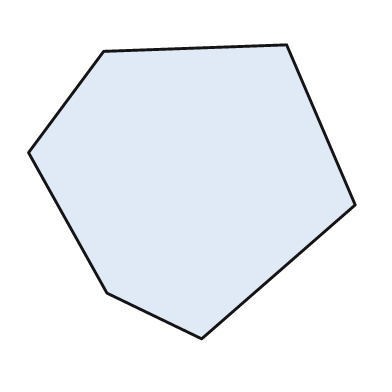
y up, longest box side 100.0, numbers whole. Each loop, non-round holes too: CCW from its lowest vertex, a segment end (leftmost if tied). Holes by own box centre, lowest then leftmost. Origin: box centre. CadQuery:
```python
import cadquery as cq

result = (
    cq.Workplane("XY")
    .moveTo(3.0, -45.0)
    .lineTo(50.0, -4.0)
    .lineTo(29.0, 45.0)
    .lineTo(-27.0, 43.0)
    .lineTo(-50.0, 12.0)
    .lineTo(-26.0, -31.0)
    .close()
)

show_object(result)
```